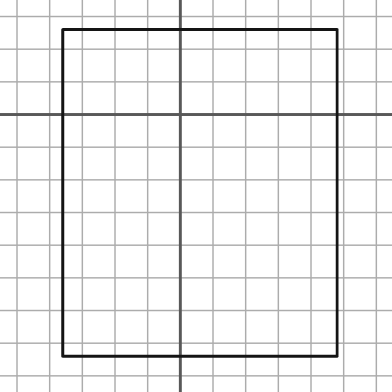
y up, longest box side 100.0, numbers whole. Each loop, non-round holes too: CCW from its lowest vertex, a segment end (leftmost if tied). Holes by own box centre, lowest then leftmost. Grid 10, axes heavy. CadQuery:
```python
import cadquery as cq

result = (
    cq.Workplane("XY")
    .moveTo(-36.0, -74.0)
    .lineTo(48.0, -74.0)
    .lineTo(48.0, 26.0)
    .lineTo(-36.0, 26.0)
    .close()
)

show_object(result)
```